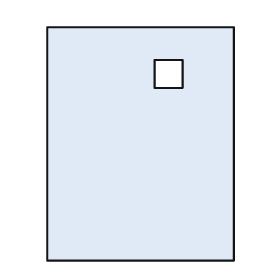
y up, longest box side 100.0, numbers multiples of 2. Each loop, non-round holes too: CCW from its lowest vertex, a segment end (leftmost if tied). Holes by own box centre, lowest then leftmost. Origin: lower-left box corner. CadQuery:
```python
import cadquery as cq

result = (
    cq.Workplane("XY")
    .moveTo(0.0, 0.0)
    .lineTo(80.0, 0.0)
    .lineTo(80.0, 100.0)
    .lineTo(0.0, 100.0)
    .close()
    .moveTo(46.0, 74.0)
    .lineTo(58.0, 74.0)
    .lineTo(58.0, 86.0)
    .lineTo(46.0, 86.0)
    .close()
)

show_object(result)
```